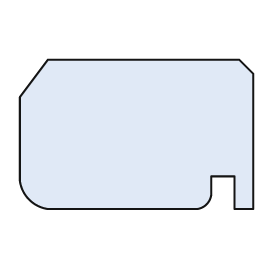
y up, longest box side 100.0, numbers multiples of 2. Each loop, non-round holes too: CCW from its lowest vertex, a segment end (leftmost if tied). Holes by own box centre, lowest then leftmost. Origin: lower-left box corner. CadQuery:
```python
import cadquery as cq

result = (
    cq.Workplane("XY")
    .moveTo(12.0, 0.0)
    .lineTo(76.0, 0.0)
    .threePointArc((80.0, 2.0), (82.0, 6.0))
    .lineTo(82.0, 14.0)
    .lineTo(92.0, 14.0)
    .lineTo(92.0, 0.0)
    .lineTo(100.0, 0.0)
    .lineTo(100.0, 58.0)
    .lineTo(94.0, 64.0)
    .lineTo(12.0, 64.0)
    .lineTo(0.0, 48.0)
    .lineTo(0.0, 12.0)
    .threePointArc((4.0, 4.0), (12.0, 0.0))
    .close()
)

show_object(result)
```